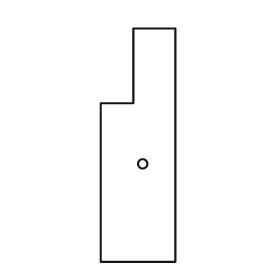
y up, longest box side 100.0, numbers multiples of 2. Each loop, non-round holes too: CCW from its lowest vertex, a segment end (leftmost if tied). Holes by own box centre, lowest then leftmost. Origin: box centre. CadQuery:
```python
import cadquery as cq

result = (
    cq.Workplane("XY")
    .moveTo(-16.0, -50.0)
    .lineTo(16.0, -50.0)
    .lineTo(16.0, 50.0)
    .lineTo(-2.0, 50.0)
    .lineTo(-2.0, 18.0)
    .lineTo(-16.0, 18.0)
    .close()
    .moveTo(2.0, -8.0)
    .circle(2.0)
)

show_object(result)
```